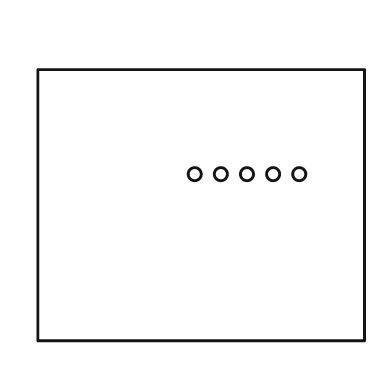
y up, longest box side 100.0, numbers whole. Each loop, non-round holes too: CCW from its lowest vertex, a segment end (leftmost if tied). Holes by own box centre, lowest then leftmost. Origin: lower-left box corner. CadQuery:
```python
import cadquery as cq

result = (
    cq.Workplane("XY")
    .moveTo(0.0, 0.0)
    .lineTo(100.0, 0.0)
    .lineTo(100.0, 83.0)
    .lineTo(0.0, 83.0)
    .close()
    .moveTo(48.0, 51.0)
    .circle(2.0)
    .moveTo(56.0, 51.0)
    .circle(2.0)
    .moveTo(64.0, 51.0)
    .circle(2.0)
    .moveTo(72.0, 51.0)
    .circle(2.0)
    .moveTo(80.0, 51.0)
    .circle(2.0)
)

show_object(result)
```